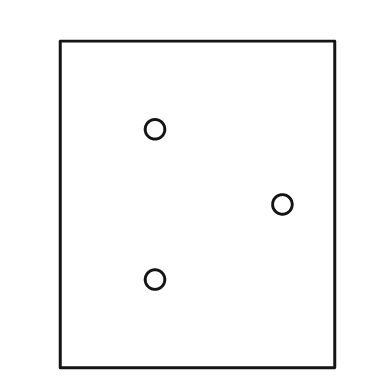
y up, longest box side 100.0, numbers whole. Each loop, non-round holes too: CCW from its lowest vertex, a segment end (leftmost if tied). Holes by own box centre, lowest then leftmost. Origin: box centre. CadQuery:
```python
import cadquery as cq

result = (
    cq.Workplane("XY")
    .moveTo(-42.0, -50.0)
    .lineTo(42.0, -50.0)
    .lineTo(42.0, 50.0)
    .lineTo(-42.0, 50.0)
    .close()
    .moveTo(-13.0, -23.0)
    .circle(3.0)
    .moveTo(26.0, 0.0)
    .circle(3.0)
    .moveTo(-13.0, 23.0)
    .circle(3.0)
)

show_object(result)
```